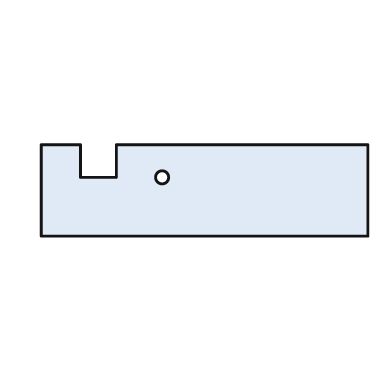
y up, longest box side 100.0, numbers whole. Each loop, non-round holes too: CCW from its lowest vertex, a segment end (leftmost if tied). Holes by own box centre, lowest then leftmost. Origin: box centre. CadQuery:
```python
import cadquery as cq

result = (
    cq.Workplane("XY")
    .moveTo(-50.0, -14.0)
    .lineTo(50.0, -14.0)
    .lineTo(50.0, 14.0)
    .lineTo(-27.0, 14.0)
    .lineTo(-27.0, 4.0)
    .lineTo(-38.0, 4.0)
    .lineTo(-38.0, 14.0)
    .lineTo(-50.0, 14.0)
    .close()
    .moveTo(-13.0, 4.0)
    .circle(2.0)
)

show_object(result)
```